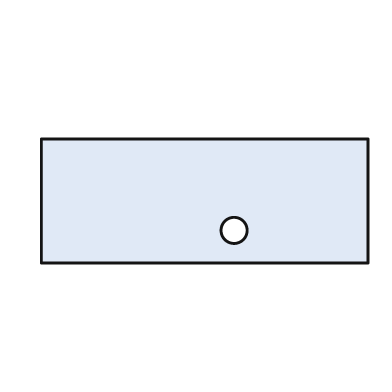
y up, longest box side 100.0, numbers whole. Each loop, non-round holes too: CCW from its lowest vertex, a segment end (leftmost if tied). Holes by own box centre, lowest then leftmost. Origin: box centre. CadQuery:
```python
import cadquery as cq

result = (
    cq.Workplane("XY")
    .moveTo(-50.0, -19.0)
    .lineTo(50.0, -19.0)
    .lineTo(50.0, 19.0)
    .lineTo(-50.0, 19.0)
    .close()
    .moveTo(9.0, -9.0)
    .circle(4.0)
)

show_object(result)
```